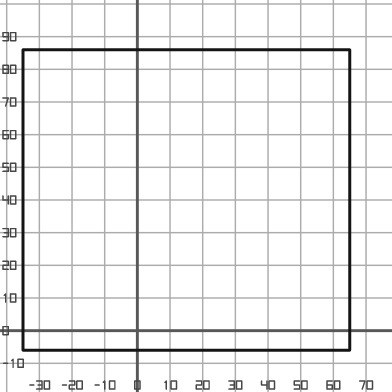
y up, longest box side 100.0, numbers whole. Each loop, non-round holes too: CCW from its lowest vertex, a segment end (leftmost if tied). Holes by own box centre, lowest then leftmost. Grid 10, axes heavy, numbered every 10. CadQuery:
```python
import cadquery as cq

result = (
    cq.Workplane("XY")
    .moveTo(-35.0, -6.0)
    .lineTo(65.0, -6.0)
    .lineTo(65.0, 86.0)
    .lineTo(-35.0, 86.0)
    .close()
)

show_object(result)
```